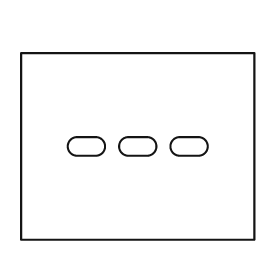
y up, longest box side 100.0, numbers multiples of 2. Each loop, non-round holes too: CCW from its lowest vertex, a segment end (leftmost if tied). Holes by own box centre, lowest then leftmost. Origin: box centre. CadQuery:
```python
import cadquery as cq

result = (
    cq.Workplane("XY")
    .moveTo(-50.0, -40.0)
    .lineTo(50.0, -40.0)
    .lineTo(50.0, 40.0)
    .lineTo(-50.0, 40.0)
    .close()
    .moveTo(-26.0, -4.0)
    .lineTo(-18.0, -4.0)
    .threePointArc((-14.0, 0.0), (-18.0, 4.0))
    .lineTo(-26.0, 4.0)
    .threePointArc((-30.0, 0.0), (-26.0, -4.0))
    .close()
    .moveTo(-4.0, -4.0)
    .lineTo(4.0, -4.0)
    .threePointArc((8.0, 0.0), (4.0, 4.0))
    .lineTo(-4.0, 4.0)
    .threePointArc((-8.0, 0.0), (-4.0, -4.0))
    .close()
    .moveTo(18.0, -4.0)
    .lineTo(26.0, -4.0)
    .threePointArc((30.0, 0.0), (26.0, 4.0))
    .lineTo(18.0, 4.0)
    .threePointArc((14.0, 0.0), (18.0, -4.0))
    .close()
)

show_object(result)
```